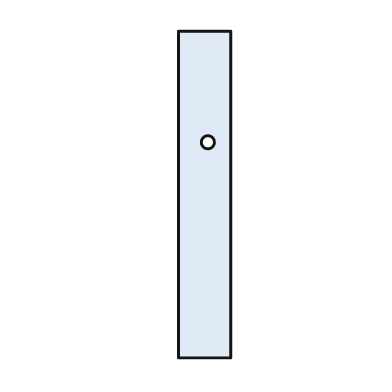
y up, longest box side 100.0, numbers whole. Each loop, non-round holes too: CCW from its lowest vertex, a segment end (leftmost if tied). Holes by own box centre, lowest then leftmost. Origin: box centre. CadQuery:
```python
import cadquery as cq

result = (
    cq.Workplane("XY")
    .moveTo(-8.0, -50.0)
    .lineTo(8.0, -50.0)
    .lineTo(8.0, 50.0)
    .lineTo(-8.0, 50.0)
    .close()
    .moveTo(1.0, 16.0)
    .circle(2.0)
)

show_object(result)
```